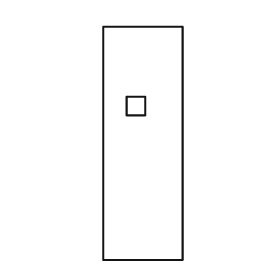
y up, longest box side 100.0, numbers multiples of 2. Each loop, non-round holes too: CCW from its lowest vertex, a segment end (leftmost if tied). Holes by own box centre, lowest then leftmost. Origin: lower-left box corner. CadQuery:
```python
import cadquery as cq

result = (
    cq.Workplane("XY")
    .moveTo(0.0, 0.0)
    .lineTo(34.0, 0.0)
    .lineTo(34.0, 100.0)
    .lineTo(0.0, 100.0)
    .close()
    .moveTo(10.0, 62.0)
    .lineTo(18.0, 62.0)
    .lineTo(18.0, 70.0)
    .lineTo(10.0, 70.0)
    .close()
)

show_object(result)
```